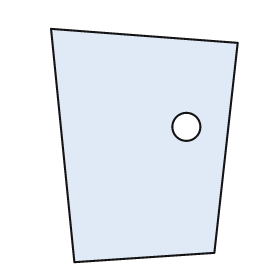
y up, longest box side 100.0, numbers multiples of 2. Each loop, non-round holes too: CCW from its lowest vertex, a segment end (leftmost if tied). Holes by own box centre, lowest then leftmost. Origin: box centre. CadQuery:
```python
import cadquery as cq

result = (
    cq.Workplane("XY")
    .moveTo(-30.0, -50.0)
    .lineTo(30.0, -46.0)
    .lineTo(40.0, 44.0)
    .lineTo(-40.0, 50.0)
    .close()
    .moveTo(18.0, 8.0)
    .circle(6.0)
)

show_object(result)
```